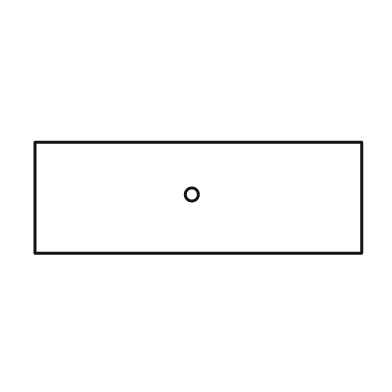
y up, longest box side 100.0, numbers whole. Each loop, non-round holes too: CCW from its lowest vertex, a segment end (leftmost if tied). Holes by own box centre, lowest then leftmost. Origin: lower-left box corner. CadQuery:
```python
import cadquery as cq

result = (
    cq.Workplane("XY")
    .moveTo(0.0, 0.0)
    .lineTo(100.0, 0.0)
    .lineTo(100.0, 34.0)
    .lineTo(0.0, 34.0)
    .close()
    .moveTo(48.0, 18.0)
    .circle(2.0)
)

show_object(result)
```